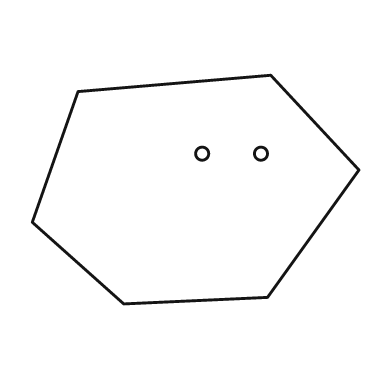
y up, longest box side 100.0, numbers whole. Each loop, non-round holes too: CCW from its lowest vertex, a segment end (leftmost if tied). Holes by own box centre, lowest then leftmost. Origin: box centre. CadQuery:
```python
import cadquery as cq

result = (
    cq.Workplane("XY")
    .moveTo(-22.0, -35.0)
    .lineTo(22.0, -33.0)
    .lineTo(50.0, 6.0)
    .lineTo(23.0, 35.0)
    .lineTo(-36.0, 30.0)
    .lineTo(-50.0, -10.0)
    .close()
    .moveTo(2.0, 11.0)
    .circle(2.0)
    .moveTo(20.0, 11.0)
    .circle(2.0)
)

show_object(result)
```